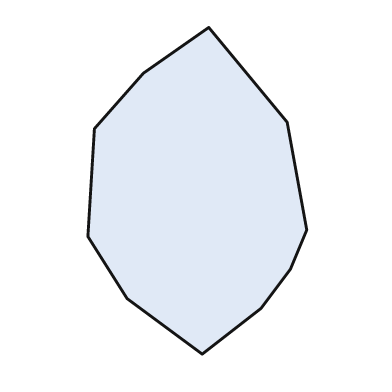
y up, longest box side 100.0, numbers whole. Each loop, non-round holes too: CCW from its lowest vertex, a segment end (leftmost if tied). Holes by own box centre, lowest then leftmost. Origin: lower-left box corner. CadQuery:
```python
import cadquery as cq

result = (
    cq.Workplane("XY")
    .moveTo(35.0, 0.0)
    .lineTo(53.0, 14.0)
    .lineTo(62.0, 26.0)
    .lineTo(67.0, 38.0)
    .lineTo(61.0, 71.0)
    .lineTo(37.0, 100.0)
    .lineTo(17.0, 86.0)
    .lineTo(2.0, 69.0)
    .lineTo(0.0, 36.0)
    .lineTo(12.0, 17.0)
    .close()
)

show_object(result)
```